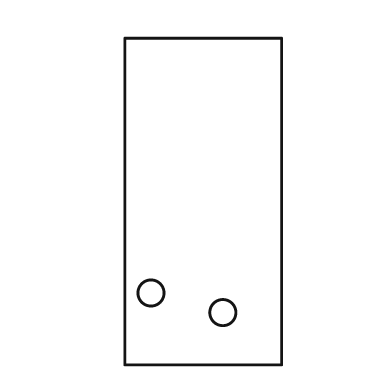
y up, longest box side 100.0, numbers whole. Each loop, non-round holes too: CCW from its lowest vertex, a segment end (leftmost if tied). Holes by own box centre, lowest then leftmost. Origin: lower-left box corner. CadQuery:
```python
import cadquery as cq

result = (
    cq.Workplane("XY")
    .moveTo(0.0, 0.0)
    .lineTo(48.0, 0.0)
    .lineTo(48.0, 100.0)
    .lineTo(0.0, 100.0)
    .close()
    .moveTo(30.0, 16.0)
    .circle(4.0)
    .moveTo(8.0, 22.0)
    .circle(4.0)
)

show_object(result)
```